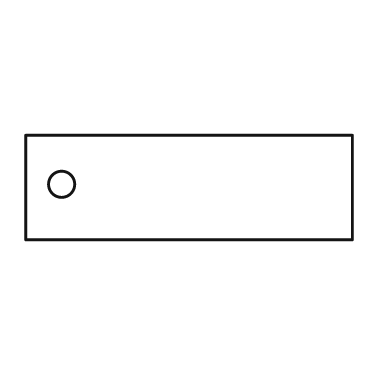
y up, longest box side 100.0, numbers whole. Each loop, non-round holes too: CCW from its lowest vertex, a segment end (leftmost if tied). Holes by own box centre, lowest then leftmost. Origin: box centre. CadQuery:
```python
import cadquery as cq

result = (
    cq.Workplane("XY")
    .moveTo(-50.0, -16.0)
    .lineTo(50.0, -16.0)
    .lineTo(50.0, 16.0)
    .lineTo(-50.0, 16.0)
    .close()
    .moveTo(-39.0, 1.0)
    .circle(4.0)
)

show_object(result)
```